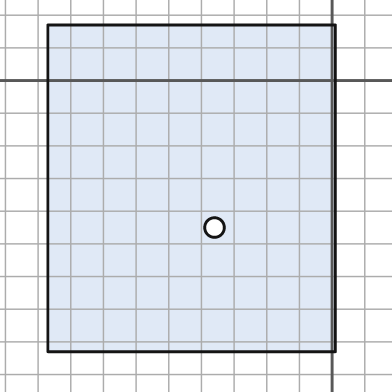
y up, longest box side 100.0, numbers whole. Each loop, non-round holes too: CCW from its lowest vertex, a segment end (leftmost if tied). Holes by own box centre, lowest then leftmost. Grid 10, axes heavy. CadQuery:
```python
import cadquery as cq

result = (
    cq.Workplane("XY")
    .moveTo(-87.0, -83.0)
    .lineTo(1.0, -83.0)
    .lineTo(1.0, 17.0)
    .lineTo(-87.0, 17.0)
    .close()
    .moveTo(-36.0, -45.0)
    .circle(3.0)
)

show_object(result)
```